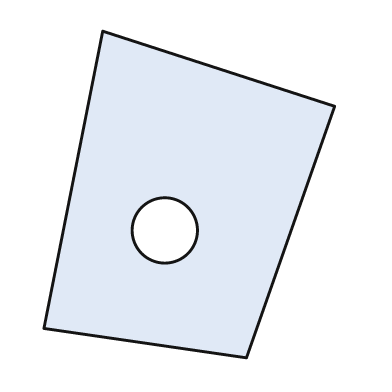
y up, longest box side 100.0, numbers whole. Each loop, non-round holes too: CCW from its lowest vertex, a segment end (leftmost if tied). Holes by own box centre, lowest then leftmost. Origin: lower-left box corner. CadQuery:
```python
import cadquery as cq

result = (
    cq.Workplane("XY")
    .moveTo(62.0, 0.0)
    .lineTo(89.0, 77.0)
    .lineTo(18.0, 100.0)
    .lineTo(0.0, 9.0)
    .close()
    .moveTo(37.0, 39.0)
    .circle(10.0)
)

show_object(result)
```